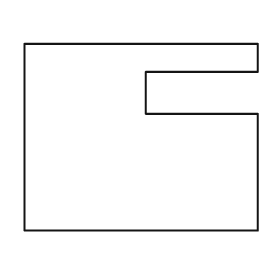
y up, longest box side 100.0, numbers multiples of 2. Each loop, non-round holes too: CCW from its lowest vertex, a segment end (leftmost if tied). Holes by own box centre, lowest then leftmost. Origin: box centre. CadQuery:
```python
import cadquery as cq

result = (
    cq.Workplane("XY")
    .moveTo(-50.0, -40.0)
    .lineTo(50.0, -40.0)
    .lineTo(50.0, 10.0)
    .lineTo(2.0, 10.0)
    .lineTo(2.0, 28.0)
    .lineTo(50.0, 28.0)
    .lineTo(50.0, 40.0)
    .lineTo(-50.0, 40.0)
    .close()
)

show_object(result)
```